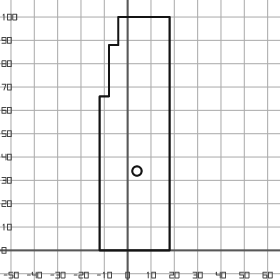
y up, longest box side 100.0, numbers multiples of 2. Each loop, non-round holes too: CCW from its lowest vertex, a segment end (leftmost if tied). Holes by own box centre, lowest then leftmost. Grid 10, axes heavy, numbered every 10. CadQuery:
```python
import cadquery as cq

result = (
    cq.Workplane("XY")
    .moveTo(-12.0, 0.0)
    .lineTo(18.0, 0.0)
    .lineTo(18.0, 100.0)
    .lineTo(-4.0, 100.0)
    .lineTo(-4.0, 88.0)
    .lineTo(-8.0, 88.0)
    .lineTo(-8.0, 66.0)
    .lineTo(-12.0, 66.0)
    .close()
    .moveTo(4.0, 34.0)
    .circle(2.0)
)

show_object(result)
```